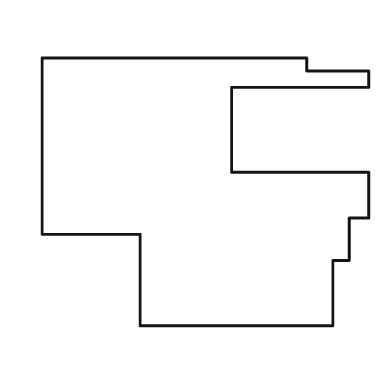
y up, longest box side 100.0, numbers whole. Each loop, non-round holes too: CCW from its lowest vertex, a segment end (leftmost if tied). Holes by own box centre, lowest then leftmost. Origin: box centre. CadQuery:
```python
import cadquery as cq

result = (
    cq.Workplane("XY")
    .moveTo(-20.0, -41.0)
    .lineTo(39.0, -41.0)
    .lineTo(39.0, -21.0)
    .lineTo(44.0, -21.0)
    .lineTo(44.0, -8.0)
    .lineTo(50.0, -8.0)
    .lineTo(50.0, 6.0)
    .lineTo(8.0, 6.0)
    .lineTo(8.0, 32.0)
    .lineTo(50.0, 32.0)
    .lineTo(50.0, 37.0)
    .lineTo(31.0, 37.0)
    .lineTo(31.0, 41.0)
    .lineTo(-50.0, 41.0)
    .lineTo(-50.0, -13.0)
    .lineTo(-20.0, -13.0)
    .close()
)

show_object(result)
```